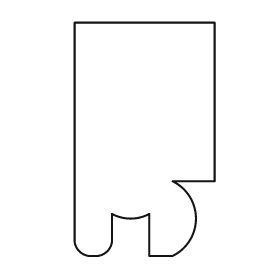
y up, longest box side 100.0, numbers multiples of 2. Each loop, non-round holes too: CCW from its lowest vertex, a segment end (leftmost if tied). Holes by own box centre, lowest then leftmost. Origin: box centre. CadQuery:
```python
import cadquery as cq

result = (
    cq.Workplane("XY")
    .moveTo(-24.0, -50.0)
    .lineTo(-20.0, -50.0)
    .threePointArc((-16.0, -48.0), (-14.0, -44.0))
    .lineTo(-14.0, -32.0)
    .threePointArc((-6.0, -34.0), (2.0, -32.0))
    .lineTo(2.0, -50.0)
    .lineTo(12.0, -50.0)
    .threePointArc((22.0, -34.0), (12.0, -18.0))
    .lineTo(30.0, -18.0)
    .lineTo(30.0, 50.0)
    .lineTo(-30.0, 50.0)
    .lineTo(-30.0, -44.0)
    .threePointArc((-28.0, -48.0), (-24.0, -50.0))
    .close()
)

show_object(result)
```